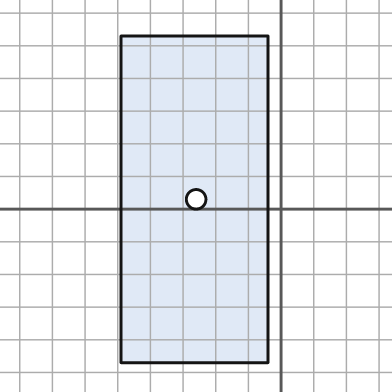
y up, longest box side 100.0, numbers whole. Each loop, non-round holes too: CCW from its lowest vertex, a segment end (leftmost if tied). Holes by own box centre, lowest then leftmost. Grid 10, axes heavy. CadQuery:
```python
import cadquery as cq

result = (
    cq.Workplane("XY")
    .moveTo(-49.0, -47.0)
    .lineTo(-4.0, -47.0)
    .lineTo(-4.0, 53.0)
    .lineTo(-49.0, 53.0)
    .close()
    .moveTo(-26.0, 3.0)
    .circle(3.0)
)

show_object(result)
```